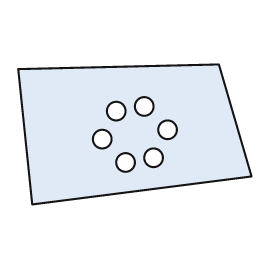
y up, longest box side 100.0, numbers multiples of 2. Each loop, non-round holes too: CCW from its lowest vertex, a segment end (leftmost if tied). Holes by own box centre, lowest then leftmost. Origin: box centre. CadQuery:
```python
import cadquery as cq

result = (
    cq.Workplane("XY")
    .moveTo(-44.0, -30.0)
    .lineTo(50.0, -18.0)
    .lineTo(36.0, 30.0)
    .lineTo(-50.0, 28.0)
    .close()
    .moveTo(-4.0, -12.0)
    .circle(4.0)
    .moveTo(8.0, -10.0)
    .circle(4.0)
    .moveTo(-14.0, -2.0)
    .circle(4.0)
    .moveTo(14.0, 2.0)
    .circle(4.0)
    .moveTo(-8.0, 10.0)
    .circle(4.0)
    .moveTo(4.0, 12.0)
    .circle(4.0)
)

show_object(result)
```